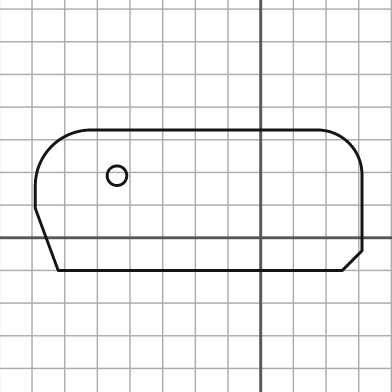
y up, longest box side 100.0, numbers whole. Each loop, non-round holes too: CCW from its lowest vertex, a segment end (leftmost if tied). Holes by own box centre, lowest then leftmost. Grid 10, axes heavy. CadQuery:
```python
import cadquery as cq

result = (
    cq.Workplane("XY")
    .moveTo(-62.0, -10.0)
    .lineTo(25.0, -10.0)
    .lineTo(31.0, -4.0)
    .lineTo(31.0, 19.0)
    .threePointArc((27.0, 29.0), (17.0, 33.0))
    .lineTo(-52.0, 33.0)
    .threePointArc((-64.0, 28.0), (-69.0, 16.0))
    .lineTo(-69.0, 9.0)
    .close()
    .moveTo(-44.0, 19.0)
    .circle(3.0)
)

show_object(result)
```